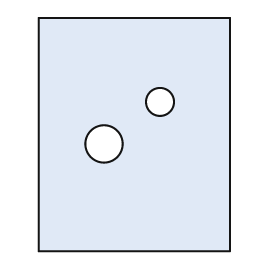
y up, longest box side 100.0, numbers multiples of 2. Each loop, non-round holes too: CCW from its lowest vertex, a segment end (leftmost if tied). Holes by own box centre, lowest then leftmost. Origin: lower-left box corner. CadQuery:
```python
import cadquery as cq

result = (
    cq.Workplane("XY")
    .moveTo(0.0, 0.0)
    .lineTo(82.0, 0.0)
    .lineTo(82.0, 100.0)
    .lineTo(0.0, 100.0)
    .close()
    .moveTo(28.0, 46.0)
    .circle(8.0)
    .moveTo(52.0, 64.0)
    .circle(6.0)
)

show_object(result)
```